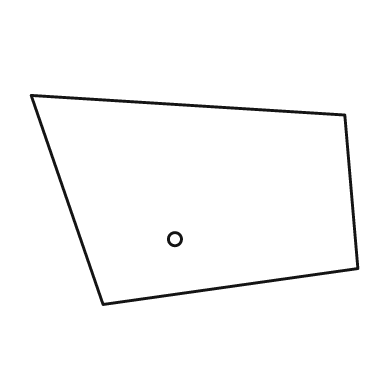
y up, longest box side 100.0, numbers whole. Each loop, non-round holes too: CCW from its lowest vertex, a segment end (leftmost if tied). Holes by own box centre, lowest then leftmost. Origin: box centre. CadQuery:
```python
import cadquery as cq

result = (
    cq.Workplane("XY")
    .moveTo(-28.0, -32.0)
    .lineTo(50.0, -21.0)
    .lineTo(46.0, 26.0)
    .lineTo(-50.0, 32.0)
    .close()
    .moveTo(-6.0, -12.0)
    .circle(2.0)
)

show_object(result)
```